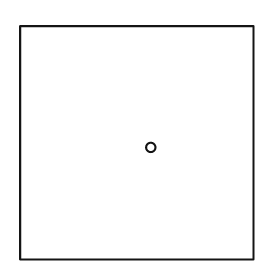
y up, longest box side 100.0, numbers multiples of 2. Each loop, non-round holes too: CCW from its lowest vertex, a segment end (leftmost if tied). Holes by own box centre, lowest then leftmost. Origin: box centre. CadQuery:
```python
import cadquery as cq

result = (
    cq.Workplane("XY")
    .moveTo(-50.0, -50.0)
    .lineTo(50.0, -50.0)
    .lineTo(50.0, 50.0)
    .lineTo(-50.0, 50.0)
    .close()
    .moveTo(6.0, -2.0)
    .circle(2.0)
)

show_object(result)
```